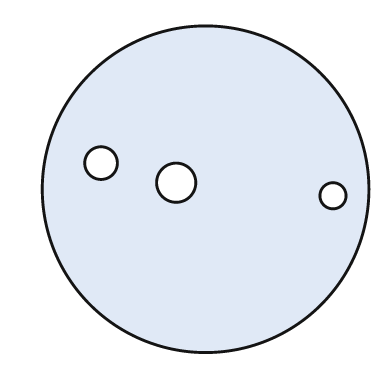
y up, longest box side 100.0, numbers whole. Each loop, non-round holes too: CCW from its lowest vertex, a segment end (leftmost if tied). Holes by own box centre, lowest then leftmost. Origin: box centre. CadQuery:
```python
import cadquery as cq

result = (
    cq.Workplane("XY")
    .moveTo(0.0, 0.0)
    .circle(50.0)
    .moveTo(39.0, -2.0)
    .circle(4.0)
    .moveTo(-9.0, 2.0)
    .circle(6.0)
    .moveTo(-32.0, 8.0)
    .circle(5.0)
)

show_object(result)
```